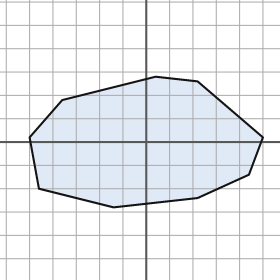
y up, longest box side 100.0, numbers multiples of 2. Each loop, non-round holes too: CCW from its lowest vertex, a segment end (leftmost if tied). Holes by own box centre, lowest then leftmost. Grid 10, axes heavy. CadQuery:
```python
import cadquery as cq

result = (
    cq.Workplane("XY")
    .moveTo(-14.0, -28.0)
    .lineTo(22.0, -24.0)
    .lineTo(44.0, -14.0)
    .lineTo(50.0, 2.0)
    .lineTo(22.0, 26.0)
    .lineTo(4.0, 28.0)
    .lineTo(-36.0, 18.0)
    .lineTo(-50.0, 2.0)
    .lineTo(-46.0, -20.0)
    .close()
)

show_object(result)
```